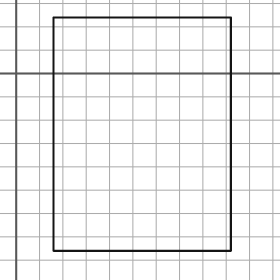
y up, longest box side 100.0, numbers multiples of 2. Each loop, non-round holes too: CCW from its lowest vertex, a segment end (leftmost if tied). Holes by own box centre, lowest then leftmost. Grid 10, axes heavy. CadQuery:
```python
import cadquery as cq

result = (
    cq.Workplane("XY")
    .moveTo(16.0, -76.0)
    .lineTo(92.0, -76.0)
    .lineTo(92.0, 24.0)
    .lineTo(16.0, 24.0)
    .close()
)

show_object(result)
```